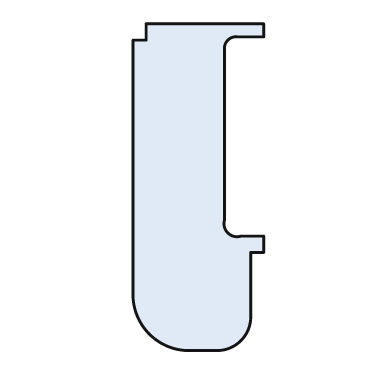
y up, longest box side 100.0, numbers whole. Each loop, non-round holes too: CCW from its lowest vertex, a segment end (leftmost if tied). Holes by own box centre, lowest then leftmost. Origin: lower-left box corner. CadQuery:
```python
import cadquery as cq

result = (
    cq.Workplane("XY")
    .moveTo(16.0, 0.0)
    .lineTo(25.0, 0.0)
    .threePointArc((33.0, 3.0), (36.0, 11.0))
    .lineTo(36.0, 30.0)
    .lineTo(40.0, 30.0)
    .lineTo(40.0, 35.0)
    .lineTo(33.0, 35.0)
    .threePointArc((29.0, 36.0), (28.0, 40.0))
    .lineTo(28.0, 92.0)
    .threePointArc((29.0, 95.0), (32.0, 96.0))
    .lineTo(40.0, 96.0)
    .lineTo(40.0, 100.0)
    .lineTo(4.0, 100.0)
    .lineTo(4.0, 95.0)
    .lineTo(0.0, 95.0)
    .lineTo(0.0, 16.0)
    .threePointArc((5.0, 5.0), (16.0, 0.0))
    .close()
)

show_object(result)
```